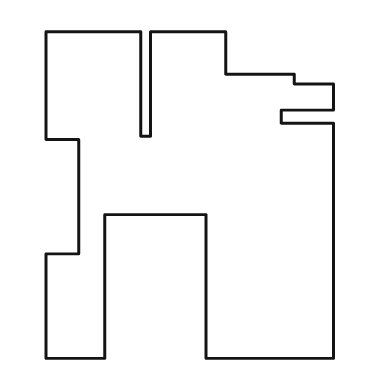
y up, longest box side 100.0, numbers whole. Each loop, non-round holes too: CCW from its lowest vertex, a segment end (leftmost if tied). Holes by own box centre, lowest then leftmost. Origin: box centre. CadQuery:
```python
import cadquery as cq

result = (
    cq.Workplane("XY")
    .moveTo(-44.0, -50.0)
    .lineTo(-26.0, -50.0)
    .lineTo(-26.0, -6.0)
    .lineTo(5.0, -6.0)
    .lineTo(5.0, -50.0)
    .lineTo(44.0, -50.0)
    .lineTo(44.0, 22.0)
    .lineTo(28.0, 22.0)
    .lineTo(28.0, 26.0)
    .lineTo(44.0, 26.0)
    .lineTo(44.0, 34.0)
    .lineTo(32.0, 34.0)
    .lineTo(32.0, 37.0)
    .lineTo(11.0, 37.0)
    .lineTo(11.0, 50.0)
    .lineTo(-12.0, 50.0)
    .lineTo(-12.0, 18.0)
    .lineTo(-15.0, 18.0)
    .lineTo(-15.0, 50.0)
    .lineTo(-44.0, 50.0)
    .lineTo(-44.0, 17.0)
    .lineTo(-34.0, 17.0)
    .lineTo(-34.0, -18.0)
    .lineTo(-44.0, -18.0)
    .close()
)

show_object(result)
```